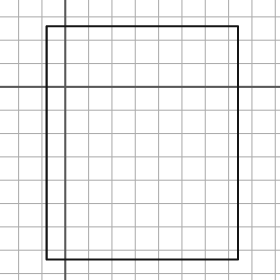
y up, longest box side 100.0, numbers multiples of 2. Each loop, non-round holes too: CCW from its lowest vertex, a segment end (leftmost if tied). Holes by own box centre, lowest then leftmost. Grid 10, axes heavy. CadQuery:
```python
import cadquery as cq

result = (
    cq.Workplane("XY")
    .moveTo(-8.0, -74.0)
    .lineTo(74.0, -74.0)
    .lineTo(74.0, 26.0)
    .lineTo(-8.0, 26.0)
    .close()
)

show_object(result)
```